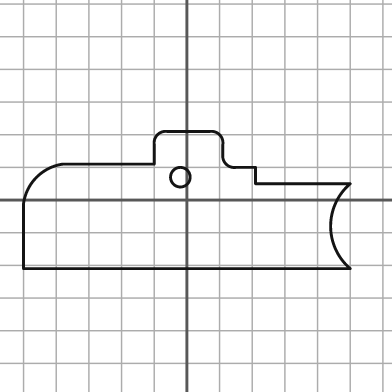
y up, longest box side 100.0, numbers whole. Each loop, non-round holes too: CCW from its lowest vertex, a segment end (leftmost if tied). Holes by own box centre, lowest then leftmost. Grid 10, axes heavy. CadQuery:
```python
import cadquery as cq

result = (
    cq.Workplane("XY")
    .moveTo(-50.0, -21.0)
    .lineTo(50.0, -21.0)
    .threePointArc((44.0, -8.0), (50.0, 5.0))
    .lineTo(21.0, 5.0)
    .lineTo(21.0, 10.0)
    .lineTo(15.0, 10.0)
    .threePointArc((12.0, 11.0), (11.0, 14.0))
    .lineTo(11.0, 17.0)
    .threePointArc((10.0, 20.0), (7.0, 21.0))
    .lineTo(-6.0, 21.0)
    .threePointArc((-9.0, 20.0), (-10.0, 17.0))
    .lineTo(-10.0, 11.0)
    .lineTo(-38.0, 11.0)
    .threePointArc((-46.0, 7.0), (-50.0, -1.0))
    .close()
    .moveTo(-2.0, 7.0)
    .circle(3.0)
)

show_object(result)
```